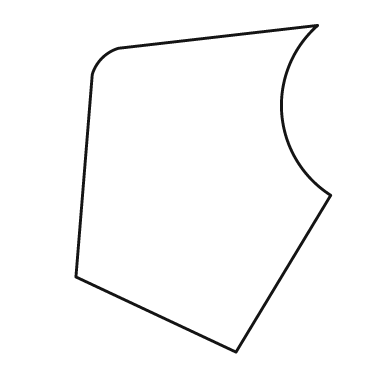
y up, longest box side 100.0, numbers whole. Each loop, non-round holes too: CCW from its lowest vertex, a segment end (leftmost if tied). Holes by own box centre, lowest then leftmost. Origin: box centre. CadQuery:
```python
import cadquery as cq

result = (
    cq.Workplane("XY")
    .moveTo(10.0, -50.0)
    .lineTo(39.0, -2.0)
    .threePointArc((24.0, 23.0), (35.0, 50.0))
    .lineTo(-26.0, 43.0)
    .threePointArc((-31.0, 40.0), (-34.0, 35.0))
    .lineTo(-39.0, -27.0)
    .close()
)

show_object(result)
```